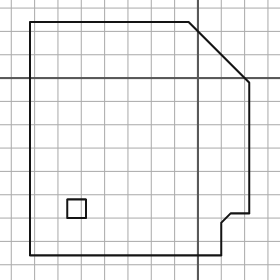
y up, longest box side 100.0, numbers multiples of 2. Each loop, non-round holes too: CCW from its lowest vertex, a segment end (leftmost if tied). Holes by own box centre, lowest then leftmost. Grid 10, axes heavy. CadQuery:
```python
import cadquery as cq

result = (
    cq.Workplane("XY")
    .moveTo(-72.0, -76.0)
    .lineTo(10.0, -76.0)
    .lineTo(10.0, -62.0)
    .lineTo(14.0, -58.0)
    .lineTo(22.0, -58.0)
    .lineTo(22.0, -2.0)
    .lineTo(-4.0, 24.0)
    .lineTo(-72.0, 24.0)
    .close()
    .moveTo(-56.0, -60.0)
    .lineTo(-48.0, -60.0)
    .lineTo(-48.0, -52.0)
    .lineTo(-56.0, -52.0)
    .close()
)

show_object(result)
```